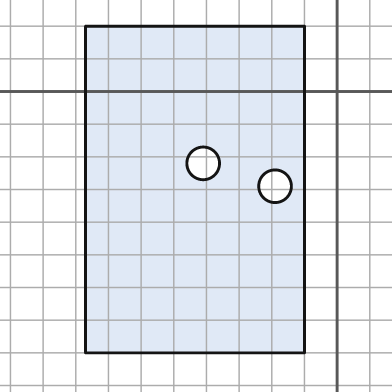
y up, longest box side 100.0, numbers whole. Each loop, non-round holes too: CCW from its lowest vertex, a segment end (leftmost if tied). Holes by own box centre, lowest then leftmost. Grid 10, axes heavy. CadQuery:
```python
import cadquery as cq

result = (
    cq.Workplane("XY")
    .moveTo(-77.0, -80.0)
    .lineTo(-10.0, -80.0)
    .lineTo(-10.0, 20.0)
    .lineTo(-77.0, 20.0)
    .close()
    .moveTo(-19.0, -29.0)
    .circle(5.0)
    .moveTo(-41.0, -22.0)
    .circle(5.0)
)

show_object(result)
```